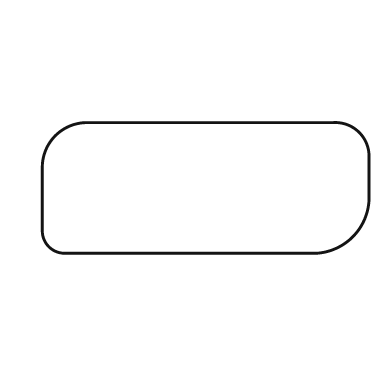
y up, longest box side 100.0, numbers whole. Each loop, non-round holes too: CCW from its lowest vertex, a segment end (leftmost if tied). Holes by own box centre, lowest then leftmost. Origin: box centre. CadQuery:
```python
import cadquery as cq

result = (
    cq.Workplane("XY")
    .moveTo(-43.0, -20.0)
    .lineTo(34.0, -20.0)
    .threePointArc((45.0, -15.0), (50.0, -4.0))
    .lineTo(50.0, 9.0)
    .threePointArc((47.0, 17.0), (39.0, 20.0))
    .lineTo(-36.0, 20.0)
    .threePointArc((-46.0, 16.0), (-50.0, 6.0))
    .lineTo(-50.0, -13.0)
    .threePointArc((-48.0, -18.0), (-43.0, -20.0))
    .close()
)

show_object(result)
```